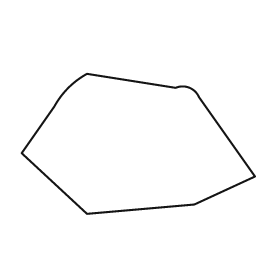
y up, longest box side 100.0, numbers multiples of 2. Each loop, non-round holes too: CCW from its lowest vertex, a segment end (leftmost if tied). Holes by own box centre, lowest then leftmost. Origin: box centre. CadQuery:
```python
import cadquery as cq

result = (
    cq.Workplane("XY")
    .moveTo(-22.0, -30.0)
    .lineTo(24.0, -26.0)
    .lineTo(50.0, -14.0)
    .lineTo(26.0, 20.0)
    .threePointArc((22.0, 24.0), (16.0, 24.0))
    .lineTo(-22.0, 30.0)
    .threePointArc((-30.0, 24.0), (-36.0, 16.0))
    .lineTo(-50.0, -4.0)
    .close()
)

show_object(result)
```